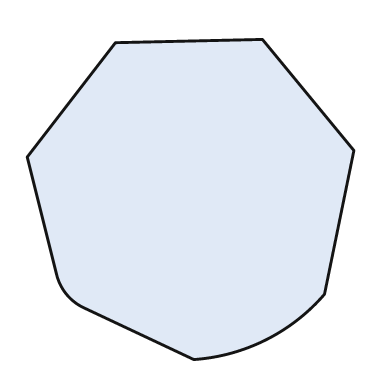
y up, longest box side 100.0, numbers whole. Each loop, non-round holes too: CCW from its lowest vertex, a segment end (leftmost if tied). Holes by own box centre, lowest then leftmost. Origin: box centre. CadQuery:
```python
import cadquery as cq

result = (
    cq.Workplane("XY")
    .moveTo(1.0, -49.0)
    .threePointArc((23.0, -43.0), (41.0, -29.0))
    .lineTo(50.0, 15.0)
    .lineTo(22.0, 49.0)
    .lineTo(-23.0, 48.0)
    .lineTo(-50.0, 13.0)
    .lineTo(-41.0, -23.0)
    .threePointArc((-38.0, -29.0), (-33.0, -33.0))
    .close()
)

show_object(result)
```